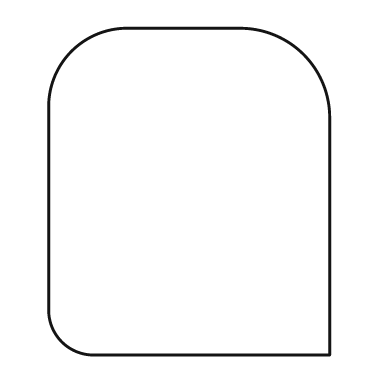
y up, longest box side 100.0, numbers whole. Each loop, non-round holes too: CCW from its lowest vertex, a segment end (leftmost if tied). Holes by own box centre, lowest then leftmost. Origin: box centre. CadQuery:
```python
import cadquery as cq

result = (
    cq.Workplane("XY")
    .moveTo(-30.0, -50.0)
    .lineTo(43.0, -50.0)
    .lineTo(43.0, 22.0)
    .threePointArc((35.0, 42.0), (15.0, 50.0))
    .lineTo(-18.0, 50.0)
    .threePointArc((-36.0, 43.0), (-43.0, 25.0))
    .lineTo(-43.0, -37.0)
    .threePointArc((-39.0, -46.0), (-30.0, -50.0))
    .close()
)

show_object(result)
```